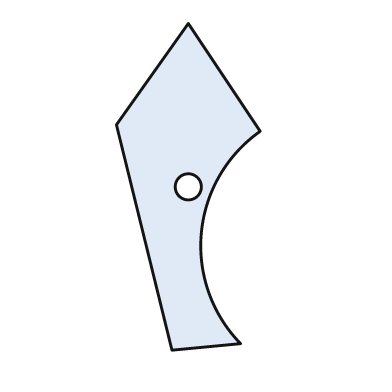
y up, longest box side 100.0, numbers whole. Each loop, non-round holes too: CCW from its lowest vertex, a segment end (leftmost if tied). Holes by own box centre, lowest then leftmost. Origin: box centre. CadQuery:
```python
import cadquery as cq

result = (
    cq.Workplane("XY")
    .moveTo(-5.0, -50.0)
    .lineTo(16.0, -48.0)
    .threePointArc((4.0, -14.0), (22.0, 17.0))
    .lineTo(0.0, 50.0)
    .lineTo(-22.0, 19.0)
    .close()
    .moveTo(0.0, 0.0)
    .circle(4.0)
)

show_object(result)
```